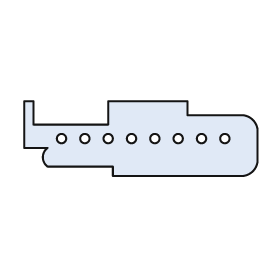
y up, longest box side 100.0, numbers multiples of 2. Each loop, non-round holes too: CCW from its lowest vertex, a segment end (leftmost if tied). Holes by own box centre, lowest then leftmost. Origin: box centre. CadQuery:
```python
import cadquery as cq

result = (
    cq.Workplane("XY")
    .moveTo(-12.0, -16.0)
    .lineTo(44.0, -16.0)
    .threePointArc((48.0, -14.0), (50.0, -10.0))
    .lineTo(50.0, 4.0)
    .threePointArc((48.0, 8.0), (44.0, 10.0))
    .lineTo(20.0, 10.0)
    .lineTo(20.0, 16.0)
    .lineTo(-14.0, 16.0)
    .lineTo(-14.0, 6.0)
    .lineTo(-46.0, 6.0)
    .lineTo(-46.0, 16.0)
    .lineTo(-50.0, 16.0)
    .lineTo(-50.0, -4.0)
    .lineTo(-40.0, -4.0)
    .threePointArc((-42.0, -8.0), (-40.0, -12.0))
    .lineTo(-12.0, -12.0)
    .close()
    .moveTo(-34.0, 0.0)
    .circle(2.0)
    .moveTo(-24.0, 0.0)
    .circle(2.0)
    .moveTo(-14.0, 0.0)
    .circle(2.0)
    .moveTo(-4.0, 0.0)
    .circle(2.0)
    .moveTo(6.0, 0.0)
    .circle(2.0)
    .moveTo(16.0, 0.0)
    .circle(2.0)
    .moveTo(26.0, 0.0)
    .circle(2.0)
    .moveTo(36.0, 0.0)
    .circle(2.0)
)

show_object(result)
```